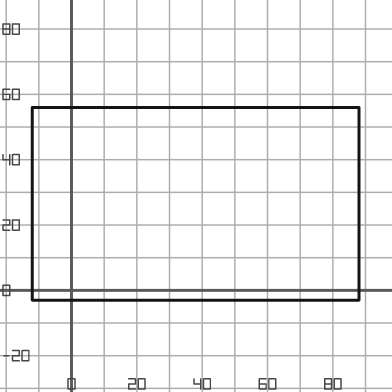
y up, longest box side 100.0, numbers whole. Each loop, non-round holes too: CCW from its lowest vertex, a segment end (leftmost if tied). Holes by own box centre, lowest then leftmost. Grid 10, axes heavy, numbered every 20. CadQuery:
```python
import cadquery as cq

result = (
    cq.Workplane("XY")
    .moveTo(-12.0, -3.0)
    .lineTo(88.0, -3.0)
    .lineTo(88.0, 56.0)
    .lineTo(-12.0, 56.0)
    .close()
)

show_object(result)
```